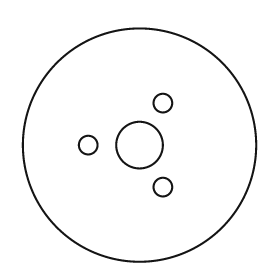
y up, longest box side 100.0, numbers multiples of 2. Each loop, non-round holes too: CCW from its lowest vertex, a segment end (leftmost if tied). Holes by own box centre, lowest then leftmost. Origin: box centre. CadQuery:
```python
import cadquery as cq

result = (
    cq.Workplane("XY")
    .moveTo(0.0, 0.0)
    .circle(50.0)
    .moveTo(10.0, -18.0)
    .circle(4.0)
    .moveTo(-22.0, 0.0)
    .circle(4.0)
    .moveTo(0.0, 0.0)
    .circle(10.0)
    .moveTo(10.0, 18.0)
    .circle(4.0)
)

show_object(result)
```